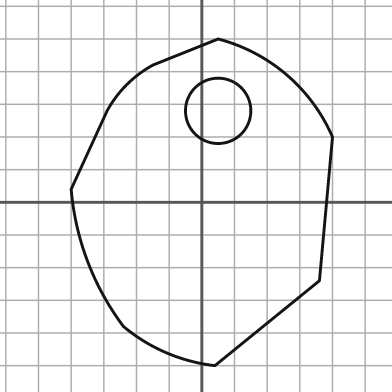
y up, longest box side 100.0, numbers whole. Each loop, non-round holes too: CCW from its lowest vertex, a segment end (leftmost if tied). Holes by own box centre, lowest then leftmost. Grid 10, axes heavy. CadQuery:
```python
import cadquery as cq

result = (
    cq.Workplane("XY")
    .moveTo(4.0, -50.0)
    .lineTo(36.0, -24.0)
    .lineTo(40.0, 20.0)
    .threePointArc((26.0, 39.0), (5.0, 50.0))
    .lineTo(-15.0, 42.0)
    .threePointArc((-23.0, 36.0), (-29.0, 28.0))
    .lineTo(-40.0, 4.0)
    .threePointArc((-35.0, -18.0), (-24.0, -38.0))
    .threePointArc((-11.0, -46.0), (4.0, -50.0))
    .close()
    .moveTo(5.0, 28.0)
    .circle(10.0)
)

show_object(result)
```